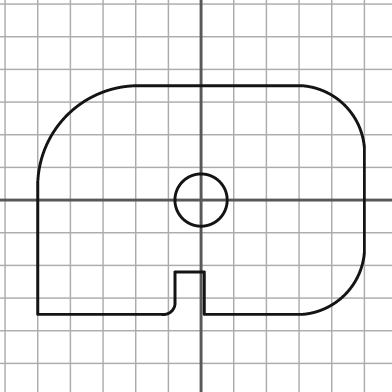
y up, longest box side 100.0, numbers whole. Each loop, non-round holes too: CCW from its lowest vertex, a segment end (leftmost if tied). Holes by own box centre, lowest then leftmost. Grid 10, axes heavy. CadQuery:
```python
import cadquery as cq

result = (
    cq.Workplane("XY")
    .moveTo(-50.0, -35.0)
    .lineTo(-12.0, -35.0)
    .threePointArc((-9.0, -34.0), (-8.0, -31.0))
    .lineTo(-8.0, -22.0)
    .lineTo(1.0, -22.0)
    .lineTo(1.0, -35.0)
    .lineTo(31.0, -35.0)
    .threePointArc((44.0, -29.0), (50.0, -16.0))
    .lineTo(50.0, 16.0)
    .threePointArc((44.0, 29.0), (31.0, 35.0))
    .lineTo(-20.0, 35.0)
    .threePointArc((-41.0, 26.0), (-50.0, 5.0))
    .close()
    .moveTo(0.0, 0.0)
    .circle(8.0)
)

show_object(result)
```